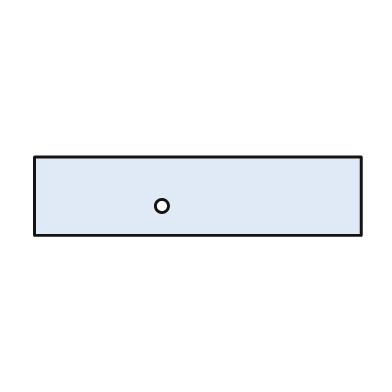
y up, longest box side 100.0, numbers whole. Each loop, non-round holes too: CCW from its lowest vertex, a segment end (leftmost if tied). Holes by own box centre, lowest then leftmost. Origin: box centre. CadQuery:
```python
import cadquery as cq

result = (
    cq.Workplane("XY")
    .moveTo(-50.0, -12.0)
    .lineTo(50.0, -12.0)
    .lineTo(50.0, 12.0)
    .lineTo(-50.0, 12.0)
    .close()
    .moveTo(-11.0, -3.0)
    .circle(2.0)
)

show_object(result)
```